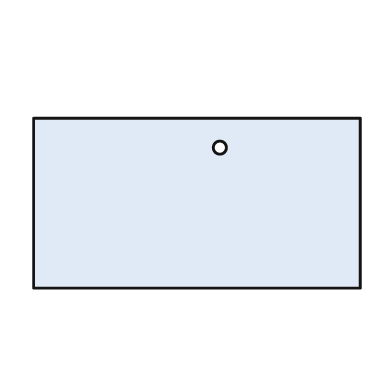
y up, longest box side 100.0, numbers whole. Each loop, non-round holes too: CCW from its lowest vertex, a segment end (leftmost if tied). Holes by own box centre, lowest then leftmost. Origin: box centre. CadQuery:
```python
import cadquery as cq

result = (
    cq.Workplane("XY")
    .moveTo(-50.0, -26.0)
    .lineTo(50.0, -26.0)
    .lineTo(50.0, 26.0)
    .lineTo(-50.0, 26.0)
    .close()
    .moveTo(7.0, 17.0)
    .circle(2.0)
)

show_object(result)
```